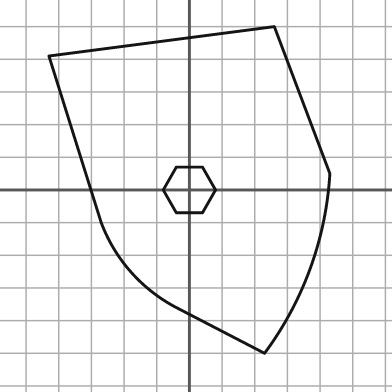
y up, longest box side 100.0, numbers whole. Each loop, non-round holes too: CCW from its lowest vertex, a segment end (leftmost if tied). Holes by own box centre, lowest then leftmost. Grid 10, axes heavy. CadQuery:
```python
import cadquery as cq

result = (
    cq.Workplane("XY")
    .moveTo(23.0, -50.0)
    .threePointArc((37.0, -24.0), (43.0, 5.0))
    .lineTo(26.0, 50.0)
    .lineTo(-43.0, 41.0)
    .lineTo(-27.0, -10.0)
    .threePointArc((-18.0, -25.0), (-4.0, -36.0))
    .close()
    .moveTo(-4.0, -7.0)
    .lineTo(4.0, -7.0)
    .lineTo(8.0, 0.0)
    .lineTo(4.0, 7.0)
    .lineTo(-4.0, 7.0)
    .lineTo(-8.0, 0.0)
    .close()
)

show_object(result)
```